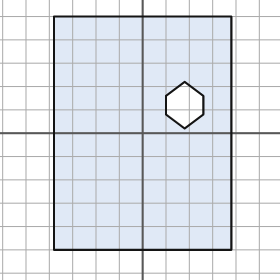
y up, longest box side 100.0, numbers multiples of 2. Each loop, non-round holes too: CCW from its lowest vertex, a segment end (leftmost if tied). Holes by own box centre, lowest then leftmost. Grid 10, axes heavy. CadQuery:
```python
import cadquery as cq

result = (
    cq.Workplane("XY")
    .moveTo(-38.0, -50.0)
    .lineTo(38.0, -50.0)
    .lineTo(38.0, 50.0)
    .lineTo(-38.0, 50.0)
    .close()
    .moveTo(18.0, 2.0)
    .lineTo(26.0, 8.0)
    .lineTo(26.0, 16.0)
    .lineTo(18.0, 22.0)
    .lineTo(10.0, 16.0)
    .lineTo(10.0, 8.0)
    .close()
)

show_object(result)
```